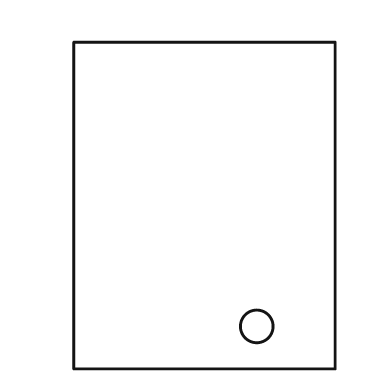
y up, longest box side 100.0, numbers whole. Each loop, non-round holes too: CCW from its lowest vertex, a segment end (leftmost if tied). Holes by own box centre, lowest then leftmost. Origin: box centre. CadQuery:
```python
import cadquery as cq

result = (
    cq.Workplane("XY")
    .moveTo(-40.0, -50.0)
    .lineTo(40.0, -50.0)
    .lineTo(40.0, 50.0)
    .lineTo(-40.0, 50.0)
    .close()
    .moveTo(16.0, -37.0)
    .circle(5.0)
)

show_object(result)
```